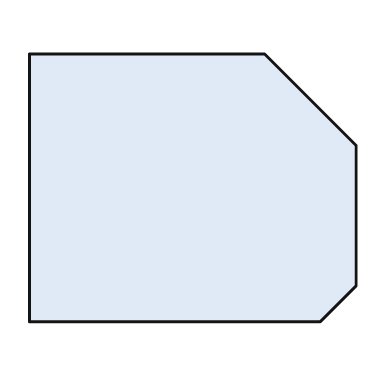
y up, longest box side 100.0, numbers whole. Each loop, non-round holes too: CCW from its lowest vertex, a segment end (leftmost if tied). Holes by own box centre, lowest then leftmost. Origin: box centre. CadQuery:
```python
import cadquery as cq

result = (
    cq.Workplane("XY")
    .moveTo(-50.0, -41.0)
    .lineTo(39.0, -41.0)
    .lineTo(50.0, -30.0)
    .lineTo(50.0, 13.0)
    .lineTo(22.0, 41.0)
    .lineTo(-50.0, 41.0)
    .close()
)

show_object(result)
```